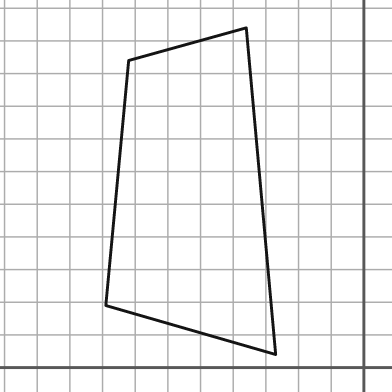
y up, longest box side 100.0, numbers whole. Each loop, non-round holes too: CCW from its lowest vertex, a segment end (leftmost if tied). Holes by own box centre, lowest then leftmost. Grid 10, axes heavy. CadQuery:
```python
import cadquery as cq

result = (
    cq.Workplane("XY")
    .moveTo(-27.0, 4.0)
    .lineTo(-36.0, 104.0)
    .lineTo(-72.0, 94.0)
    .lineTo(-79.0, 19.0)
    .close()
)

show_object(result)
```